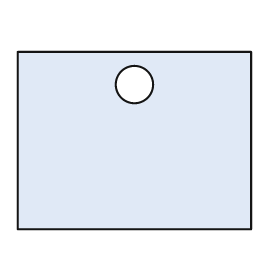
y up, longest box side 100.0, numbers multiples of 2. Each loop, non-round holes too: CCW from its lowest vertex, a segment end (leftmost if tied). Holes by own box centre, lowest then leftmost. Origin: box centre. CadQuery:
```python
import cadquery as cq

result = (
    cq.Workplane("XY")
    .moveTo(-50.0, -38.0)
    .lineTo(50.0, -38.0)
    .lineTo(50.0, 38.0)
    .lineTo(-50.0, 38.0)
    .close()
    .moveTo(0.0, 24.0)
    .circle(8.0)
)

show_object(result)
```